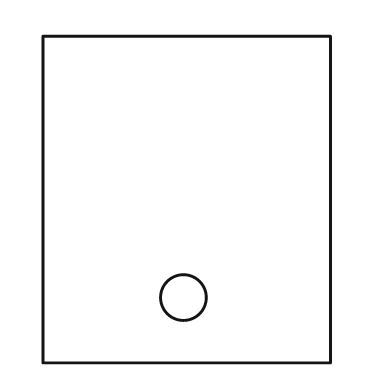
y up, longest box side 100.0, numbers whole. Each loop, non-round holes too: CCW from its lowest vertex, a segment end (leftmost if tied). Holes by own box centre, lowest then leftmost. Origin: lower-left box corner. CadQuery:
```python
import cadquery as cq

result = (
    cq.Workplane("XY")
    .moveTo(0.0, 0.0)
    .lineTo(88.0, 0.0)
    .lineTo(88.0, 100.0)
    .lineTo(0.0, 100.0)
    .close()
    .moveTo(43.0, 20.0)
    .circle(7.0)
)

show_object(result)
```